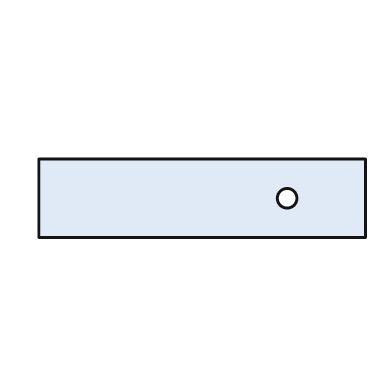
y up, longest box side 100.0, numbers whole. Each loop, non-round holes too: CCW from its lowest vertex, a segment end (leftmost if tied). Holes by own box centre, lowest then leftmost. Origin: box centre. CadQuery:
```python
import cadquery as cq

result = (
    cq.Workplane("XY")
    .moveTo(-50.0, -12.0)
    .lineTo(50.0, -12.0)
    .lineTo(50.0, 12.0)
    .lineTo(-50.0, 12.0)
    .close()
    .moveTo(26.0, 0.0)
    .circle(3.0)
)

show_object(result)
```